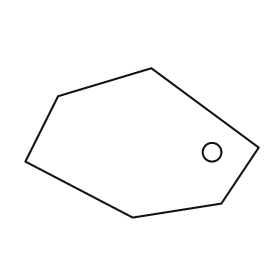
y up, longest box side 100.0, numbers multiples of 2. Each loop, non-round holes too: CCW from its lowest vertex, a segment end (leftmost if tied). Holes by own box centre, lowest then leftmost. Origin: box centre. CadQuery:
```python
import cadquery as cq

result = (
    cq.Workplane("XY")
    .moveTo(-4.0, -32.0)
    .lineTo(34.0, -26.0)
    .lineTo(50.0, -2.0)
    .lineTo(4.0, 32.0)
    .lineTo(-36.0, 20.0)
    .lineTo(-50.0, -8.0)
    .close()
    .moveTo(30.0, -4.0)
    .circle(4.0)
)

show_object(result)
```